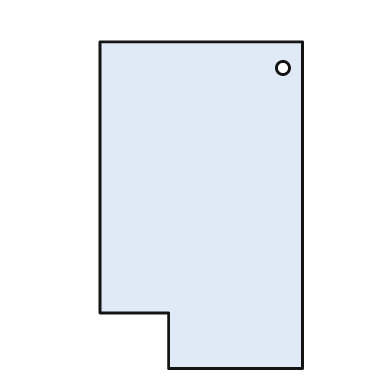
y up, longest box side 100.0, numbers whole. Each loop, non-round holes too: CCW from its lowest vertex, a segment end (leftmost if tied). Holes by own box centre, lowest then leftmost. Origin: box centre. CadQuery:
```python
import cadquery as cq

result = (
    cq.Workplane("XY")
    .moveTo(-10.0, -50.0)
    .lineTo(31.0, -50.0)
    .lineTo(31.0, 50.0)
    .lineTo(-31.0, 50.0)
    .lineTo(-31.0, -33.0)
    .lineTo(-10.0, -33.0)
    .close()
    .moveTo(25.0, 42.0)
    .circle(2.0)
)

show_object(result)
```